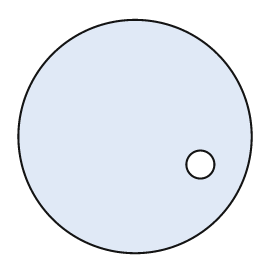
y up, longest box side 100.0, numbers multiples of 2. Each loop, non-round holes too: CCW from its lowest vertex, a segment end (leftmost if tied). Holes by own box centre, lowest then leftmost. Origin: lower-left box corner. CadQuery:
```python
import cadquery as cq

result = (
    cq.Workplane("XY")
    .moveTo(50.0, 50.0)
    .circle(50.0)
    .moveTo(78.0, 38.0)
    .circle(6.0)
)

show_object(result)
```